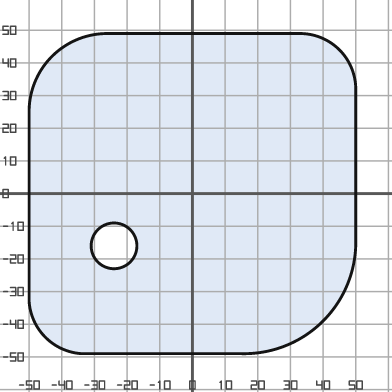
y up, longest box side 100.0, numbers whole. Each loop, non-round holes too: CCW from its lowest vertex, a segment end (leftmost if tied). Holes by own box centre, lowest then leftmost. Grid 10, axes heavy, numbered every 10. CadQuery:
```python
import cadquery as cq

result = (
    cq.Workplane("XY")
    .moveTo(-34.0, -49.0)
    .lineTo(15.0, -49.0)
    .threePointArc((40.0, -39.0), (50.0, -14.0))
    .lineTo(50.0, 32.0)
    .threePointArc((45.0, 44.0), (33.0, 49.0))
    .lineTo(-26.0, 49.0)
    .threePointArc((-43.0, 42.0), (-50.0, 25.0))
    .lineTo(-50.0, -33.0)
    .threePointArc((-45.0, -44.0), (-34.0, -49.0))
    .close()
    .moveTo(-24.0, -16.0)
    .circle(7.0)
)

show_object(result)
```